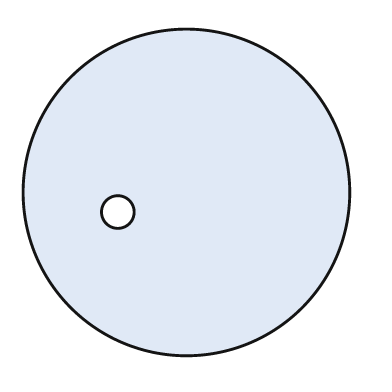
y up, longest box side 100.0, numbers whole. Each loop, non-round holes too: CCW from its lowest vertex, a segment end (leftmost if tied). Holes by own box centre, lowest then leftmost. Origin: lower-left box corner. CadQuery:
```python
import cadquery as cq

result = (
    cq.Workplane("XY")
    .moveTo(50.0, 50.0)
    .circle(50.0)
    .moveTo(29.0, 44.0)
    .circle(5.0)
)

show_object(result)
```